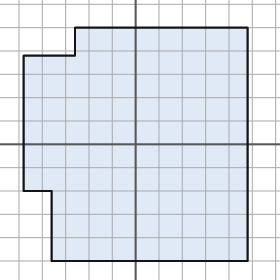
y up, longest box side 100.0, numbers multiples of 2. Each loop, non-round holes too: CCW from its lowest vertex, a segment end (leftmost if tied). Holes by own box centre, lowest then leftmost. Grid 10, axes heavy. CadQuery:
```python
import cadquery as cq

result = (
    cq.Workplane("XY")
    .moveTo(-36.0, -50.0)
    .lineTo(48.0, -50.0)
    .lineTo(48.0, 50.0)
    .lineTo(-26.0, 50.0)
    .lineTo(-26.0, 38.0)
    .lineTo(-48.0, 38.0)
    .lineTo(-48.0, -20.0)
    .lineTo(-36.0, -20.0)
    .close()
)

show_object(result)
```